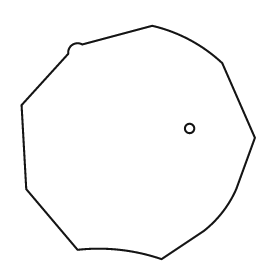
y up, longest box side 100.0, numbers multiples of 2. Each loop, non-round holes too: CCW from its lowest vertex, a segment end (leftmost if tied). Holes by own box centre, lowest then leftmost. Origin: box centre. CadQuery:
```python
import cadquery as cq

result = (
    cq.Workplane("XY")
    .moveTo(10.0, -50.0)
    .lineTo(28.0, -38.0)
    .threePointArc((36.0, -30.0), (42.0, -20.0))
    .lineTo(50.0, 2.0)
    .lineTo(36.0, 34.0)
    .threePointArc((22.0, 44.0), (6.0, 50.0))
    .lineTo(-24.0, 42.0)
    .threePointArc((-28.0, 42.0), (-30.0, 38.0))
    .lineTo(-50.0, 16.0)
    .lineTo(-48.0, -20.0)
    .lineTo(-26.0, -46.0)
    .threePointArc((-8.0, -46.0), (10.0, -50.0))
    .close()
    .moveTo(22.0, 6.0)
    .circle(2.0)
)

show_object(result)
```